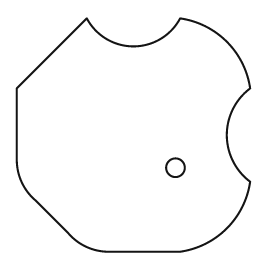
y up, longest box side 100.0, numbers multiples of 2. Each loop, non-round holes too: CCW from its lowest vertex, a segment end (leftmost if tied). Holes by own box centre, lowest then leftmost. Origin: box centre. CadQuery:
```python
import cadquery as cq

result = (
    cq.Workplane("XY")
    .moveTo(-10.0, -50.0)
    .lineTo(20.0, -50.0)
    .threePointArc((40.0, -40.0), (50.0, -20.0))
    .threePointArc((40.0, 0.0), (50.0, 20.0))
    .threePointArc((40.0, 40.0), (20.0, 50.0))
    .threePointArc((0.0, 38.0), (-20.0, 50.0))
    .lineTo(-50.0, 20.0)
    .lineTo(-50.0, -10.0)
    .threePointArc((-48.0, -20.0), (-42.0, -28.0))
    .lineTo(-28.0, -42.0)
    .threePointArc((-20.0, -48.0), (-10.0, -50.0))
    .close()
    .moveTo(18.0, -14.0)
    .circle(4.0)
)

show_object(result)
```